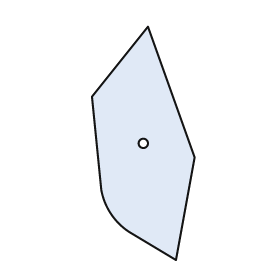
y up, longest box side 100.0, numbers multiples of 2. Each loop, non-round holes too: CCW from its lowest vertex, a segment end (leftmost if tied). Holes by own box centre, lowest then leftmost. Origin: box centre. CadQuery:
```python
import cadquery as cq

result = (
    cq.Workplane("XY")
    .moveTo(14.0, -50.0)
    .lineTo(22.0, -6.0)
    .lineTo(2.0, 50.0)
    .lineTo(-22.0, 20.0)
    .lineTo(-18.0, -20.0)
    .threePointArc((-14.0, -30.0), (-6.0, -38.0))
    .close()
    .moveTo(0.0, 0.0)
    .circle(2.0)
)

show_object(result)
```